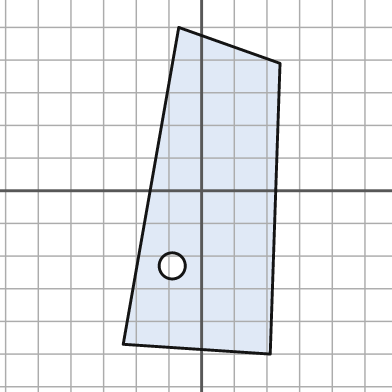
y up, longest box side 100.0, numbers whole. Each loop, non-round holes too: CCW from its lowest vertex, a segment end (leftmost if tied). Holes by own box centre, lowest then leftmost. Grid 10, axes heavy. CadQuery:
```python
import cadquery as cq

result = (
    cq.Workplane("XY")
    .moveTo(21.0, -50.0)
    .lineTo(24.0, 39.0)
    .lineTo(-7.0, 50.0)
    .lineTo(-24.0, -47.0)
    .close()
    .moveTo(-9.0, -23.0)
    .circle(4.0)
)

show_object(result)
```